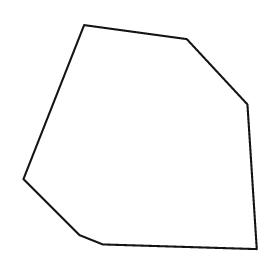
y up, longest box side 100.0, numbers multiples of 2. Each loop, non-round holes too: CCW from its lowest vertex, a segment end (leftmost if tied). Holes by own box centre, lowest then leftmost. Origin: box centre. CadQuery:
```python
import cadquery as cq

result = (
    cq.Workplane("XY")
    .moveTo(50.0, -48.0)
    .lineTo(46.0, 14.0)
    .lineTo(20.0, 42.0)
    .lineTo(-24.0, 48.0)
    .lineTo(-50.0, -18.0)
    .lineTo(-26.0, -42.0)
    .lineTo(-16.0, -46.0)
    .close()
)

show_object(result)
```